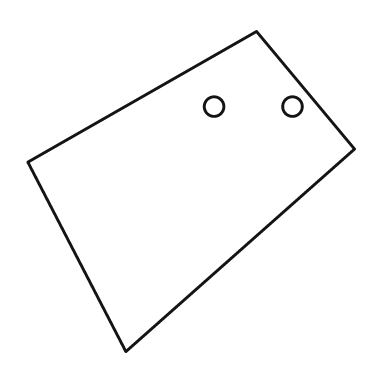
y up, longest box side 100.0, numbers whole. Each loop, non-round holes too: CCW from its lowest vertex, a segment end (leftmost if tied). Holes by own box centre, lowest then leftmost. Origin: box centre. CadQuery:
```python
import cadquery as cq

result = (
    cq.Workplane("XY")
    .moveTo(-20.0, -49.0)
    .lineTo(50.0, 13.0)
    .lineTo(20.0, 49.0)
    .lineTo(-50.0, 9.0)
    .close()
    .moveTo(7.0, 26.0)
    .circle(3.0)
    .moveTo(31.0, 26.0)
    .circle(3.0)
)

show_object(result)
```